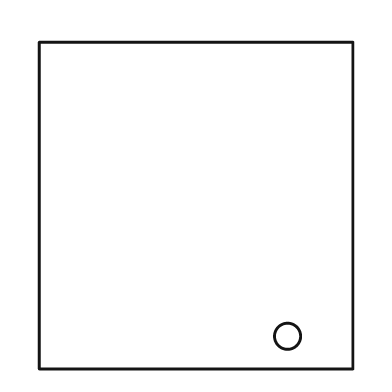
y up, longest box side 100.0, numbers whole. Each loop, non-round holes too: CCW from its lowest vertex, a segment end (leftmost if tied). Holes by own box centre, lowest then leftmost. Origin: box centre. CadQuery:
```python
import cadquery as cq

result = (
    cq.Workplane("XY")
    .moveTo(-48.0, -50.0)
    .lineTo(48.0, -50.0)
    .lineTo(48.0, 50.0)
    .lineTo(-48.0, 50.0)
    .close()
    .moveTo(28.0, -40.0)
    .circle(4.0)
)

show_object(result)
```